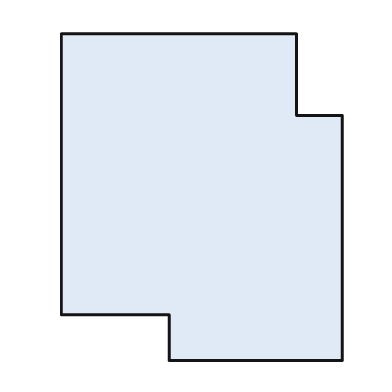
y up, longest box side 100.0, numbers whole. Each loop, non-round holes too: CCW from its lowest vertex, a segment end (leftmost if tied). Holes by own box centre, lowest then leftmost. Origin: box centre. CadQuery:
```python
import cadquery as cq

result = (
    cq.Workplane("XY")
    .moveTo(-10.0, -50.0)
    .lineTo(43.0, -50.0)
    .lineTo(43.0, 25.0)
    .lineTo(29.0, 25.0)
    .lineTo(29.0, 50.0)
    .lineTo(-43.0, 50.0)
    .lineTo(-43.0, -36.0)
    .lineTo(-10.0, -36.0)
    .close()
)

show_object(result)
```